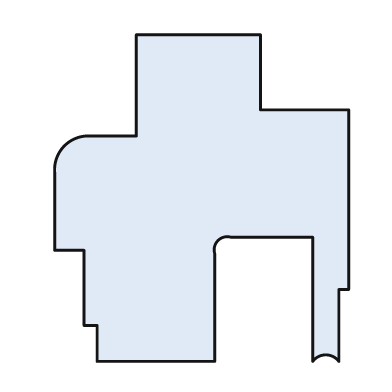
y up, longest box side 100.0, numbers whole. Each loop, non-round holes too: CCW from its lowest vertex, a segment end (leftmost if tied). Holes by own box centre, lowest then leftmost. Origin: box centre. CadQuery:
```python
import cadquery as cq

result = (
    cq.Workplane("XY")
    .moveTo(-32.0, -50.0)
    .lineTo(4.0, -50.0)
    .lineTo(4.0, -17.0)
    .threePointArc((5.0, -13.0), (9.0, -12.0))
    .lineTo(34.0, -12.0)
    .lineTo(34.0, -50.0)
    .threePointArc((38.0, -48.0), (42.0, -50.0))
    .lineTo(42.0, -28.0)
    .lineTo(45.0, -28.0)
    .lineTo(45.0, 27.0)
    .lineTo(18.0, 27.0)
    .lineTo(18.0, 50.0)
    .lineTo(-20.0, 50.0)
    .lineTo(-20.0, 19.0)
    .lineTo(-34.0, 19.0)
    .threePointArc((-42.0, 16.0), (-45.0, 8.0))
    .lineTo(-45.0, -16.0)
    .lineTo(-36.0, -16.0)
    .lineTo(-36.0, -39.0)
    .lineTo(-32.0, -39.0)
    .close()
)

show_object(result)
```